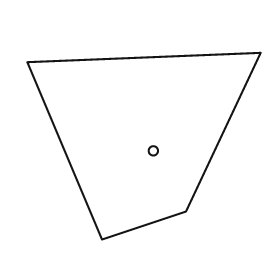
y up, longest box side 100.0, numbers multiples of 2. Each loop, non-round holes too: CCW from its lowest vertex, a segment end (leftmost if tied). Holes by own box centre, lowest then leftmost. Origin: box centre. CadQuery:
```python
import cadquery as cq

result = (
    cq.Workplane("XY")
    .moveTo(-18.0, -40.0)
    .lineTo(18.0, -28.0)
    .lineTo(50.0, 40.0)
    .lineTo(-50.0, 36.0)
    .close()
    .moveTo(4.0, -2.0)
    .circle(2.0)
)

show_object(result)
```